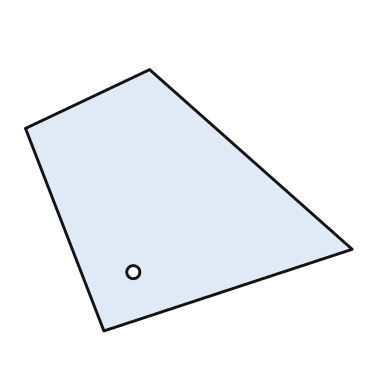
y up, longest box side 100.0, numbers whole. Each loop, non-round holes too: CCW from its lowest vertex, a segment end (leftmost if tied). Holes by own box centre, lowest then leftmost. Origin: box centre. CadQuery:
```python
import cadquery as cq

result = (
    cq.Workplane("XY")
    .moveTo(-26.0, -40.0)
    .lineTo(50.0, -15.0)
    .lineTo(-12.0, 40.0)
    .lineTo(-50.0, 22.0)
    .close()
    .moveTo(-17.0, -22.0)
    .circle(2.0)
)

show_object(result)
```